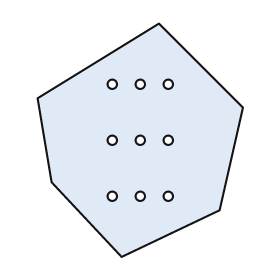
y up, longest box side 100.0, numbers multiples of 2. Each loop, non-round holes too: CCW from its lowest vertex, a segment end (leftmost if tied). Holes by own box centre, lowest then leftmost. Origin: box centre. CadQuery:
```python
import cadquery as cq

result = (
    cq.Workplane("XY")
    .moveTo(-8.0, -50.0)
    .lineTo(34.0, -30.0)
    .lineTo(44.0, 14.0)
    .lineTo(8.0, 50.0)
    .lineTo(-44.0, 18.0)
    .lineTo(-38.0, -18.0)
    .close()
    .moveTo(-12.0, -24.0)
    .circle(2.0)
    .moveTo(0.0, -24.0)
    .circle(2.0)
    .moveTo(12.0, -24.0)
    .circle(2.0)
    .moveTo(-12.0, 0.0)
    .circle(2.0)
    .moveTo(0.0, 0.0)
    .circle(2.0)
    .moveTo(12.0, 0.0)
    .circle(2.0)
    .moveTo(-12.0, 24.0)
    .circle(2.0)
    .moveTo(0.0, 24.0)
    .circle(2.0)
    .moveTo(12.0, 24.0)
    .circle(2.0)
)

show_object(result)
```